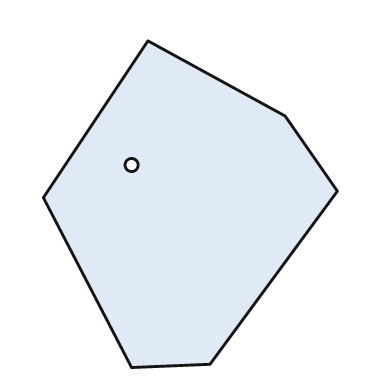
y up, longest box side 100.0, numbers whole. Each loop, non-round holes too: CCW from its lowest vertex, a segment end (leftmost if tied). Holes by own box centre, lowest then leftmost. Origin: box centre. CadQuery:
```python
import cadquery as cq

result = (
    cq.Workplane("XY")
    .moveTo(-18.0, -50.0)
    .lineTo(6.0, -49.0)
    .lineTo(45.0, 4.0)
    .lineTo(29.0, 27.0)
    .lineTo(-13.0, 50.0)
    .lineTo(-45.0, 2.0)
    .close()
    .moveTo(-18.0, 12.0)
    .circle(2.0)
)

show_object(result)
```